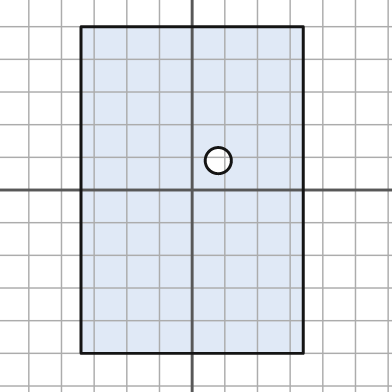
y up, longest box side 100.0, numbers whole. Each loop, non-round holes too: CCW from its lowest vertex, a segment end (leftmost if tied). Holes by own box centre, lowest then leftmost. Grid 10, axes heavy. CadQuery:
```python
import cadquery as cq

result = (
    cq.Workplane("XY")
    .moveTo(-34.0, -50.0)
    .lineTo(34.0, -50.0)
    .lineTo(34.0, 50.0)
    .lineTo(-34.0, 50.0)
    .close()
    .moveTo(8.0, 9.0)
    .circle(4.0)
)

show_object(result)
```